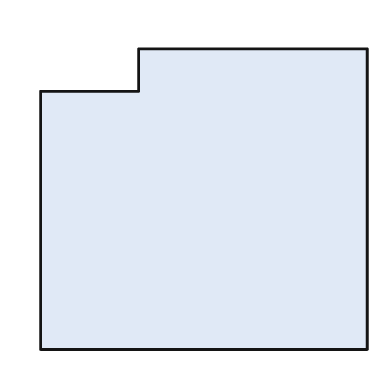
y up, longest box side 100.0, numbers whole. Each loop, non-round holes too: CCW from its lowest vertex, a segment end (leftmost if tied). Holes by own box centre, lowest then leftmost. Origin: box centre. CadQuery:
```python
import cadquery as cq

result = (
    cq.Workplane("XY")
    .moveTo(-50.0, -46.0)
    .lineTo(50.0, -46.0)
    .lineTo(50.0, 46.0)
    .lineTo(-20.0, 46.0)
    .lineTo(-20.0, 33.0)
    .lineTo(-50.0, 33.0)
    .close()
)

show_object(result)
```